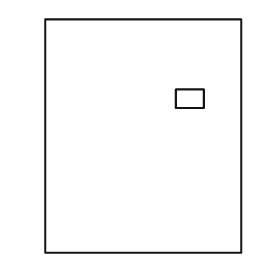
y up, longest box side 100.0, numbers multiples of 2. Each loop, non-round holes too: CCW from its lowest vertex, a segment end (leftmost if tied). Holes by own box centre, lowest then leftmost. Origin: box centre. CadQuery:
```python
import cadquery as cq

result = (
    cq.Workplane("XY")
    .moveTo(-42.0, -50.0)
    .lineTo(42.0, -50.0)
    .lineTo(42.0, 50.0)
    .lineTo(-42.0, 50.0)
    .close()
    .moveTo(14.0, 12.0)
    .lineTo(26.0, 12.0)
    .lineTo(26.0, 20.0)
    .lineTo(14.0, 20.0)
    .close()
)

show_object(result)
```